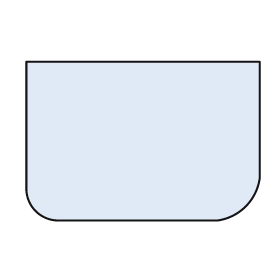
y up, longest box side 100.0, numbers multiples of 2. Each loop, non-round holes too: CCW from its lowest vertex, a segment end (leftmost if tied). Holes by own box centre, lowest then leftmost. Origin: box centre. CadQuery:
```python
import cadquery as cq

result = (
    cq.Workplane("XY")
    .moveTo(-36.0, -34.0)
    .lineTo(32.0, -34.0)
    .threePointArc((44.0, -28.0), (50.0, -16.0))
    .lineTo(50.0, 34.0)
    .lineTo(-50.0, 34.0)
    .lineTo(-50.0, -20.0)
    .threePointArc((-46.0, -30.0), (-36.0, -34.0))
    .close()
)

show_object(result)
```